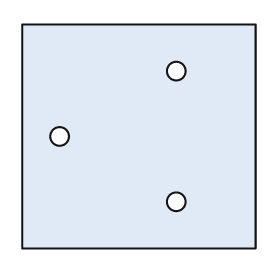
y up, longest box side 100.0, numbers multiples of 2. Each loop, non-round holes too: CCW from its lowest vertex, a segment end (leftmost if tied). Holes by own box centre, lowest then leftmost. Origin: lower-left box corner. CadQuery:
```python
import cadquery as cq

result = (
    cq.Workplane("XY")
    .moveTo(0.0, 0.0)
    .lineTo(100.0, 0.0)
    .lineTo(100.0, 96.0)
    .lineTo(0.0, 96.0)
    .close()
    .moveTo(66.0, 20.0)
    .circle(4.0)
    .moveTo(16.0, 48.0)
    .circle(4.0)
    .moveTo(66.0, 76.0)
    .circle(4.0)
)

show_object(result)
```